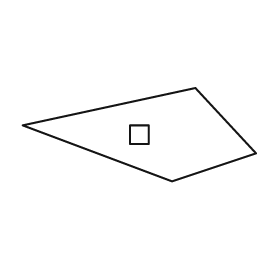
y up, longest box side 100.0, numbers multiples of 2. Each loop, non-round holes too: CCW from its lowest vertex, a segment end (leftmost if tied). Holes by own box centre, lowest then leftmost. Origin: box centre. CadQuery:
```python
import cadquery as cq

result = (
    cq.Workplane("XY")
    .moveTo(14.0, -20.0)
    .lineTo(50.0, -8.0)
    .lineTo(24.0, 20.0)
    .lineTo(-50.0, 4.0)
    .close()
    .moveTo(-4.0, -4.0)
    .lineTo(4.0, -4.0)
    .lineTo(4.0, 4.0)
    .lineTo(-4.0, 4.0)
    .close()
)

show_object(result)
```